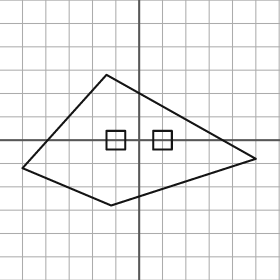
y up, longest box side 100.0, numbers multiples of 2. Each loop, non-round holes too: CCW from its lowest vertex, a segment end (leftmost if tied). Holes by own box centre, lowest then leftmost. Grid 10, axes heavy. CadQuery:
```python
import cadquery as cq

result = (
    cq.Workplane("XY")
    .moveTo(-12.0, -28.0)
    .lineTo(50.0, -8.0)
    .lineTo(-14.0, 28.0)
    .lineTo(-50.0, -12.0)
    .close()
    .moveTo(-14.0, -4.0)
    .lineTo(-6.0, -4.0)
    .lineTo(-6.0, 4.0)
    .lineTo(-14.0, 4.0)
    .close()
    .moveTo(6.0, -4.0)
    .lineTo(14.0, -4.0)
    .lineTo(14.0, 4.0)
    .lineTo(6.0, 4.0)
    .close()
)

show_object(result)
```